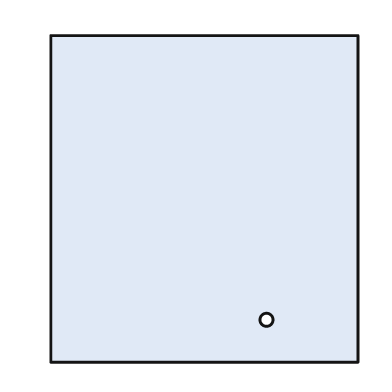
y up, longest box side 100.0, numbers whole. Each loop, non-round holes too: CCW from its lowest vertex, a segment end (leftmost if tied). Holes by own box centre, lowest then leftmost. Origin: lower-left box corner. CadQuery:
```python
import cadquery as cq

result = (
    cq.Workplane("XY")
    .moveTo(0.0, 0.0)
    .lineTo(94.0, 0.0)
    .lineTo(94.0, 100.0)
    .lineTo(0.0, 100.0)
    .close()
    .moveTo(66.0, 13.0)
    .circle(2.0)
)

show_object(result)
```